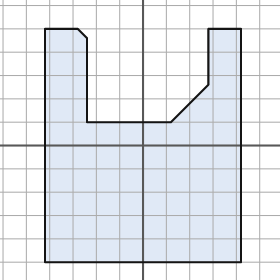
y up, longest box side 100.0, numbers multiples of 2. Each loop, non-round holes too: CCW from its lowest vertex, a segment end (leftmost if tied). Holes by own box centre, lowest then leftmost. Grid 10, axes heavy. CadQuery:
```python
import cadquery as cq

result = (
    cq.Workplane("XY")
    .moveTo(-42.0, -50.0)
    .lineTo(42.0, -50.0)
    .lineTo(42.0, 50.0)
    .lineTo(28.0, 50.0)
    .lineTo(28.0, 26.0)
    .lineTo(12.0, 10.0)
    .lineTo(-24.0, 10.0)
    .lineTo(-24.0, 46.0)
    .lineTo(-28.0, 50.0)
    .lineTo(-42.0, 50.0)
    .close()
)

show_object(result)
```